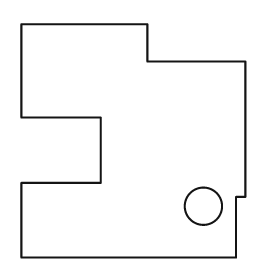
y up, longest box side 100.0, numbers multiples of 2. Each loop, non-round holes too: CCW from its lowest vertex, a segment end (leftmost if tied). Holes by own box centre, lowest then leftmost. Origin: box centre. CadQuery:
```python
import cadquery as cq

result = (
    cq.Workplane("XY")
    .moveTo(-48.0, -50.0)
    .lineTo(44.0, -50.0)
    .lineTo(44.0, -24.0)
    .lineTo(48.0, -24.0)
    .lineTo(48.0, 34.0)
    .lineTo(6.0, 34.0)
    .lineTo(6.0, 50.0)
    .lineTo(-48.0, 50.0)
    .lineTo(-48.0, 10.0)
    .lineTo(-14.0, 10.0)
    .lineTo(-14.0, -18.0)
    .lineTo(-48.0, -18.0)
    .close()
    .moveTo(30.0, -28.0)
    .circle(8.0)
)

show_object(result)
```